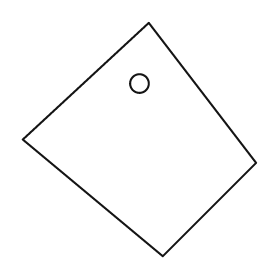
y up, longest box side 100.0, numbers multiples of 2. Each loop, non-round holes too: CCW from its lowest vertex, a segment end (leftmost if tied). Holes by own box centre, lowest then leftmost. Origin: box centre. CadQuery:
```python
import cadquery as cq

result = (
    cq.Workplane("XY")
    .moveTo(10.0, -50.0)
    .lineTo(50.0, -10.0)
    .lineTo(4.0, 50.0)
    .lineTo(-50.0, 0.0)
    .close()
    .moveTo(0.0, 24.0)
    .circle(4.0)
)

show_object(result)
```